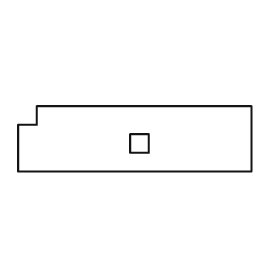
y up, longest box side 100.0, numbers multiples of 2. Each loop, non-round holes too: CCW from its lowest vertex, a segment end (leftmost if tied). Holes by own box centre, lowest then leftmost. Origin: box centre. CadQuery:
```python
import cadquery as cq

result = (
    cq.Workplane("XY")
    .moveTo(-50.0, -14.0)
    .lineTo(50.0, -14.0)
    .lineTo(50.0, 14.0)
    .lineTo(-42.0, 14.0)
    .lineTo(-42.0, 6.0)
    .lineTo(-50.0, 6.0)
    .close()
    .moveTo(-2.0, -6.0)
    .lineTo(6.0, -6.0)
    .lineTo(6.0, 2.0)
    .lineTo(-2.0, 2.0)
    .close()
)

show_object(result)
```